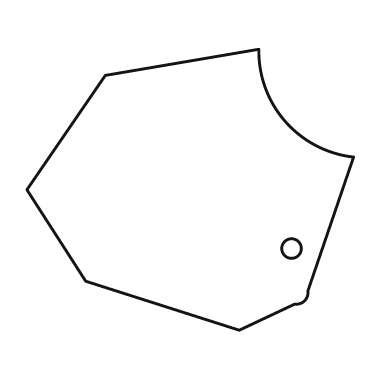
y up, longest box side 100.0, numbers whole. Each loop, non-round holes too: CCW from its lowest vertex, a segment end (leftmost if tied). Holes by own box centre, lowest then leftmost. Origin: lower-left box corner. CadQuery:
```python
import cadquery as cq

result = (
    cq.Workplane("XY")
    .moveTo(65.0, 0.0)
    .lineTo(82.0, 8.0)
    .threePointArc((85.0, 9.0), (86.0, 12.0))
    .lineTo(100.0, 53.0)
    .threePointArc((79.0, 64.0), (71.0, 86.0))
    .lineTo(24.0, 78.0)
    .lineTo(0.0, 43.0)
    .lineTo(18.0, 15.0)
    .close()
    .moveTo(81.0, 25.0)
    .circle(3.0)
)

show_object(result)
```